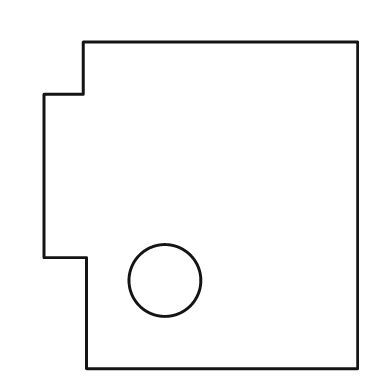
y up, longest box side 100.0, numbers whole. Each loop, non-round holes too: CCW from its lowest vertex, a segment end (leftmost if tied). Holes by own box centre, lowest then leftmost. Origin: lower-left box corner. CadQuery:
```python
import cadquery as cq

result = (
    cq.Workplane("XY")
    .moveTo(13.0, 0.0)
    .lineTo(96.0, 0.0)
    .lineTo(96.0, 100.0)
    .lineTo(12.0, 100.0)
    .lineTo(12.0, 84.0)
    .lineTo(0.0, 84.0)
    .lineTo(0.0, 34.0)
    .lineTo(13.0, 34.0)
    .close()
    .moveTo(37.0, 27.0)
    .circle(11.0)
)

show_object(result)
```